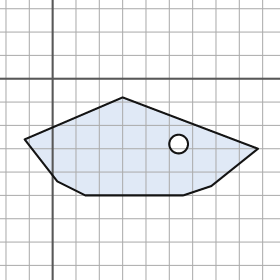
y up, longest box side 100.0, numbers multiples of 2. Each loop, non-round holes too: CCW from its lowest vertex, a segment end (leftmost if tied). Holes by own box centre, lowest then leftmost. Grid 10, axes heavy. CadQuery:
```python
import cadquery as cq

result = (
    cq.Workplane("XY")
    .moveTo(14.0, -50.0)
    .lineTo(56.0, -50.0)
    .lineTo(68.0, -46.0)
    .lineTo(88.0, -30.0)
    .lineTo(30.0, -8.0)
    .lineTo(-12.0, -26.0)
    .lineTo(2.0, -44.0)
    .close()
    .moveTo(54.0, -28.0)
    .circle(4.0)
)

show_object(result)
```